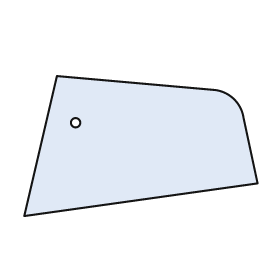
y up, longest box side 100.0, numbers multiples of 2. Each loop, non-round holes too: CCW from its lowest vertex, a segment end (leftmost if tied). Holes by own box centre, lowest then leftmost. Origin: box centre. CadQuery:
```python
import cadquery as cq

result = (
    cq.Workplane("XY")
    .moveTo(-50.0, -30.0)
    .lineTo(50.0, -16.0)
    .lineTo(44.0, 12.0)
    .threePointArc((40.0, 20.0), (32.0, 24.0))
    .lineTo(-36.0, 30.0)
    .close()
    .moveTo(-28.0, 10.0)
    .circle(2.0)
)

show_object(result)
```